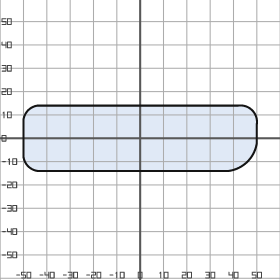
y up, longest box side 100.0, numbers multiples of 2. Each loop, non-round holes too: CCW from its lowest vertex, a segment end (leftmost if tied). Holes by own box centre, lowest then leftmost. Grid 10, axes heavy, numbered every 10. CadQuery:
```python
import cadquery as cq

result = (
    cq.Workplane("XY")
    .moveTo(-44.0, -14.0)
    .lineTo(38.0, -14.0)
    .threePointArc((46.0, -10.0), (50.0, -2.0))
    .lineTo(50.0, 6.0)
    .threePointArc((48.0, 12.0), (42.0, 14.0))
    .lineTo(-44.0, 14.0)
    .threePointArc((-48.0, 12.0), (-50.0, 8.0))
    .lineTo(-50.0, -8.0)
    .threePointArc((-48.0, -12.0), (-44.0, -14.0))
    .close()
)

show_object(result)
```